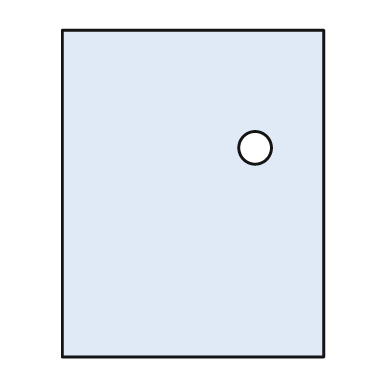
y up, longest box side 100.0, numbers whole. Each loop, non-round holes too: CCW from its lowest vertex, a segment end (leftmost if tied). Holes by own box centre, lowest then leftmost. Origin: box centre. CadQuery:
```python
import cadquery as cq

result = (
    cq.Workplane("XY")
    .moveTo(-40.0, -50.0)
    .lineTo(40.0, -50.0)
    .lineTo(40.0, 50.0)
    .lineTo(-40.0, 50.0)
    .close()
    .moveTo(19.0, 14.0)
    .circle(5.0)
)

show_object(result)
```